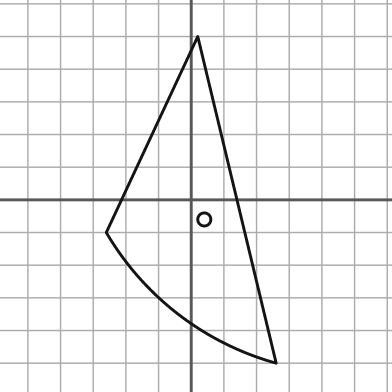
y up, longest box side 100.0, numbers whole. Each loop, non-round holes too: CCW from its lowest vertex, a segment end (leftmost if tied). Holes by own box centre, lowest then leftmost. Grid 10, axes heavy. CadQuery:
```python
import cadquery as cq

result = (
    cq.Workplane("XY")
    .moveTo(26.0, -50.0)
    .lineTo(2.0, 50.0)
    .lineTo(-26.0, -10.0)
    .threePointArc((-4.0, -35.0), (26.0, -50.0))
    .close()
    .moveTo(4.0, -6.0)
    .circle(2.0)
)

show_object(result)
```